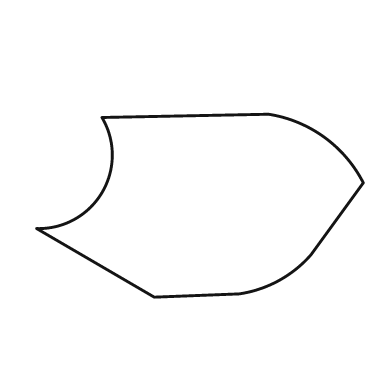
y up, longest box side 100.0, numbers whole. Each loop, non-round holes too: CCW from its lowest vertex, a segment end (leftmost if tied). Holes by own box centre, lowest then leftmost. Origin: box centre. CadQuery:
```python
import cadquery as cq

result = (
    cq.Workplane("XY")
    .moveTo(-14.0, -28.0)
    .lineTo(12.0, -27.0)
    .threePointArc((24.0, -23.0), (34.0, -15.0))
    .lineTo(50.0, 7.0)
    .threePointArc((38.0, 21.0), (21.0, 28.0))
    .lineTo(-30.0, 27.0)
    .threePointArc((-30.0, 4.0), (-50.0, -7.0))
    .close()
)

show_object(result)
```